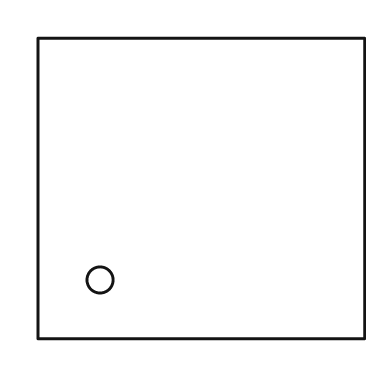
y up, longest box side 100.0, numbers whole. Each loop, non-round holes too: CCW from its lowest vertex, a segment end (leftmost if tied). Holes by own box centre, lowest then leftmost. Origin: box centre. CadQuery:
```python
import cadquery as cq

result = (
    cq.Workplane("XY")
    .moveTo(-50.0, -46.0)
    .lineTo(50.0, -46.0)
    .lineTo(50.0, 46.0)
    .lineTo(-50.0, 46.0)
    .close()
    .moveTo(-31.0, -28.0)
    .circle(4.0)
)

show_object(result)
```